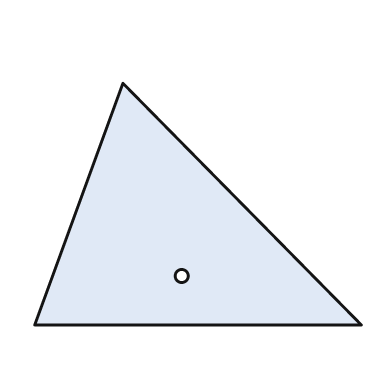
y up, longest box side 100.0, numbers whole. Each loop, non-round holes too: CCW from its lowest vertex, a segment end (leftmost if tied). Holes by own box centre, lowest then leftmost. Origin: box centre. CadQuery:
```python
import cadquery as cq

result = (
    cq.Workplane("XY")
    .moveTo(-50.0, -37.0)
    .lineTo(50.0, -37.0)
    .lineTo(-23.0, 37.0)
    .close()
    .moveTo(-5.0, -22.0)
    .circle(2.0)
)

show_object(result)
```